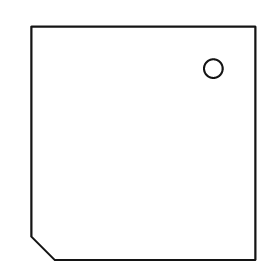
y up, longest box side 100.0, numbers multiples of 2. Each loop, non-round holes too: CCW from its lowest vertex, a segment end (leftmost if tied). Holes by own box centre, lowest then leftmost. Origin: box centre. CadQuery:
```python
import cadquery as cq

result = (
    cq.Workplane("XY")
    .moveTo(-38.0, -50.0)
    .lineTo(48.0, -50.0)
    .lineTo(48.0, 50.0)
    .lineTo(-48.0, 50.0)
    .lineTo(-48.0, -40.0)
    .close()
    .moveTo(30.0, 32.0)
    .circle(4.0)
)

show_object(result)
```